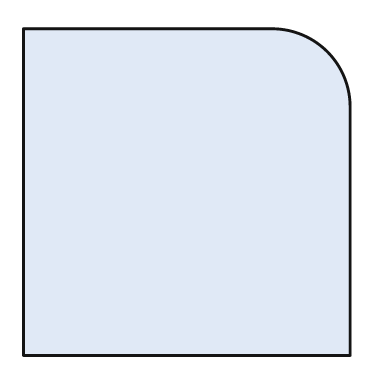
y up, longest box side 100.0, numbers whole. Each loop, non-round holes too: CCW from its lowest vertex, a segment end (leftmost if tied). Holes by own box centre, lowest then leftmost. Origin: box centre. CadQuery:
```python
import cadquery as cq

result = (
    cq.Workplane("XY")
    .moveTo(-50.0, -50.0)
    .lineTo(50.0, -50.0)
    .lineTo(50.0, 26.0)
    .threePointArc((43.0, 43.0), (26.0, 50.0))
    .lineTo(-50.0, 50.0)
    .close()
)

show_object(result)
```